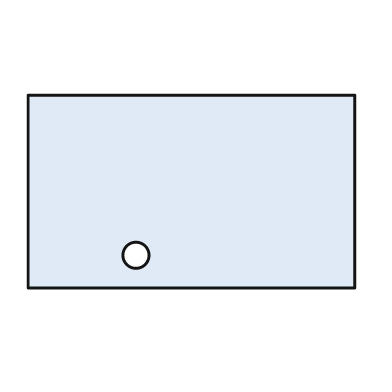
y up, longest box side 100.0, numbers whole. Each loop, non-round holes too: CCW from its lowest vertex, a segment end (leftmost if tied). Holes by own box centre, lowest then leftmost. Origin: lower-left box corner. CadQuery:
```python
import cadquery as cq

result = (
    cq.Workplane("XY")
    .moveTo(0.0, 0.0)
    .lineTo(100.0, 0.0)
    .lineTo(100.0, 59.0)
    .lineTo(0.0, 59.0)
    .close()
    .moveTo(33.0, 10.0)
    .circle(4.0)
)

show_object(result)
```